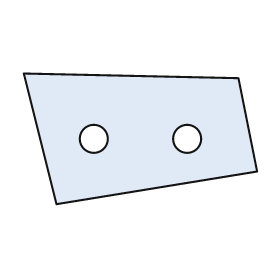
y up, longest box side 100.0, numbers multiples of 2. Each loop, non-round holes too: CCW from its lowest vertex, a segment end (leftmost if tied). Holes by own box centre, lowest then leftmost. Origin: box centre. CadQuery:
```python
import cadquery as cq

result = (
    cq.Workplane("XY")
    .moveTo(-36.0, -28.0)
    .lineTo(50.0, -14.0)
    .lineTo(42.0, 26.0)
    .lineTo(-50.0, 28.0)
    .close()
    .moveTo(-20.0, 0.0)
    .circle(6.0)
    .moveTo(20.0, 0.0)
    .circle(6.0)
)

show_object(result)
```